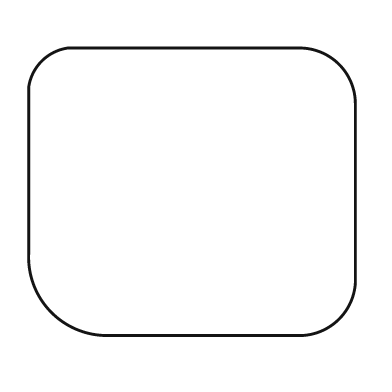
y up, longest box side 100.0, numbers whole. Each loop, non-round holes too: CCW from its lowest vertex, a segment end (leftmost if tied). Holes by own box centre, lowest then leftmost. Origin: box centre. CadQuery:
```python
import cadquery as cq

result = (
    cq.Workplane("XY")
    .moveTo(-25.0, -44.0)
    .lineTo(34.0, -44.0)
    .threePointArc((45.0, -39.0), (50.0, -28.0))
    .lineTo(50.0, 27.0)
    .threePointArc((45.0, 39.0), (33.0, 44.0))
    .lineTo(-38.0, 44.0)
    .threePointArc((-46.0, 40.0), (-50.0, 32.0))
    .lineTo(-50.0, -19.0)
    .threePointArc((-43.0, -37.0), (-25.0, -44.0))
    .close()
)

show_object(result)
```